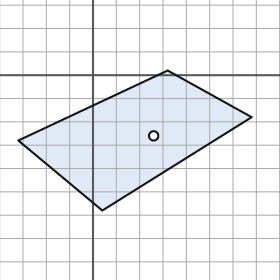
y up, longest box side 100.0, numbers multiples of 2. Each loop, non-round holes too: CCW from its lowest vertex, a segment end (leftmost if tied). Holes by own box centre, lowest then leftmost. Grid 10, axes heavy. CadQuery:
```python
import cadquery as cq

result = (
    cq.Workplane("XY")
    .moveTo(4.0, -58.0)
    .lineTo(68.0, -18.0)
    .lineTo(32.0, 2.0)
    .lineTo(-32.0, -28.0)
    .close()
    .moveTo(26.0, -26.0)
    .circle(2.0)
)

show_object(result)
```